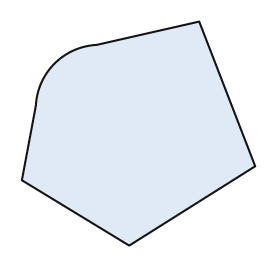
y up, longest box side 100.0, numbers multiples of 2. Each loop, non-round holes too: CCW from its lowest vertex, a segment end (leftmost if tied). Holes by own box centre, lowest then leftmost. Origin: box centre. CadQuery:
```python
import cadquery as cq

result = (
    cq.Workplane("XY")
    .moveTo(-4.0, -48.0)
    .lineTo(50.0, -14.0)
    .lineTo(26.0, 48.0)
    .lineTo(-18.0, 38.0)
    .threePointArc((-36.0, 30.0), (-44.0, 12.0))
    .lineTo(-50.0, -20.0)
    .close()
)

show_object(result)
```